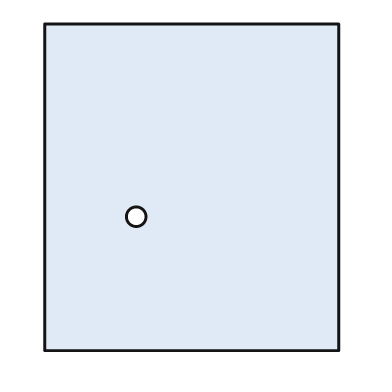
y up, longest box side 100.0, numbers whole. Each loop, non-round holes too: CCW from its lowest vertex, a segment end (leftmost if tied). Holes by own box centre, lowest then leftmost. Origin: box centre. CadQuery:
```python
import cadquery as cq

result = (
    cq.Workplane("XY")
    .moveTo(-45.0, -50.0)
    .lineTo(45.0, -50.0)
    .lineTo(45.0, 50.0)
    .lineTo(-45.0, 50.0)
    .close()
    .moveTo(-17.0, -9.0)
    .circle(3.0)
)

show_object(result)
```